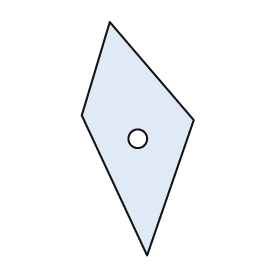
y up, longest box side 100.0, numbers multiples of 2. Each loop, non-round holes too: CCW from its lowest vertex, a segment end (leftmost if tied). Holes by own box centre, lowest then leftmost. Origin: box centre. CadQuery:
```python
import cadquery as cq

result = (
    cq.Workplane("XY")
    .moveTo(4.0, -50.0)
    .lineTo(24.0, 8.0)
    .lineTo(-12.0, 50.0)
    .lineTo(-24.0, 10.0)
    .close()
    .moveTo(0.0, 0.0)
    .circle(4.0)
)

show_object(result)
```